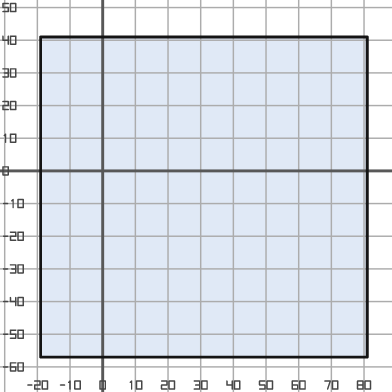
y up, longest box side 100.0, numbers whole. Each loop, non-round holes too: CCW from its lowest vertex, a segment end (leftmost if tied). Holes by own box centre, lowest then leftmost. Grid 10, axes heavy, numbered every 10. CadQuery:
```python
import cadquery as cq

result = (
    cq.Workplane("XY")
    .moveTo(-19.0, -57.0)
    .lineTo(81.0, -57.0)
    .lineTo(81.0, 41.0)
    .lineTo(-19.0, 41.0)
    .close()
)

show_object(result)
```